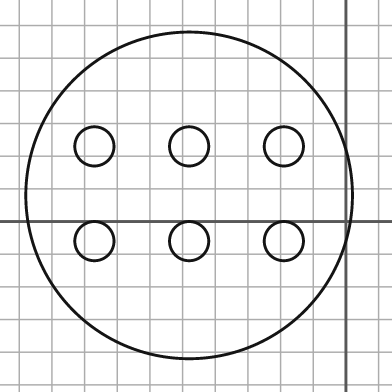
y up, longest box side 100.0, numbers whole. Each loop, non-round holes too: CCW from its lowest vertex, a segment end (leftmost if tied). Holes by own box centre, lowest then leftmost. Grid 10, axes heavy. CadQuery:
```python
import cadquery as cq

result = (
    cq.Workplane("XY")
    .moveTo(-48.0, 8.0)
    .circle(50.0)
    .moveTo(-77.0, -6.0)
    .circle(6.0)
    .moveTo(-48.0, -6.0)
    .circle(6.0)
    .moveTo(-19.0, -6.0)
    .circle(6.0)
    .moveTo(-77.0, 23.0)
    .circle(6.0)
    .moveTo(-48.0, 23.0)
    .circle(6.0)
    .moveTo(-19.0, 23.0)
    .circle(6.0)
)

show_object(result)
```